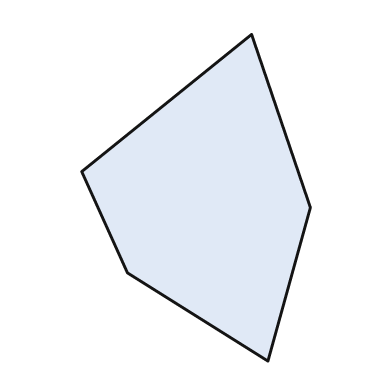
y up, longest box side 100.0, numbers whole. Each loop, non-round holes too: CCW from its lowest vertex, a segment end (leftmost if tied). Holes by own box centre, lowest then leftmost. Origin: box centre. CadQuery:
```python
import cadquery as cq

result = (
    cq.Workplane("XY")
    .moveTo(22.0, -50.0)
    .lineTo(35.0, -3.0)
    .lineTo(17.0, 50.0)
    .lineTo(-35.0, 8.0)
    .lineTo(-21.0, -23.0)
    .close()
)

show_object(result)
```